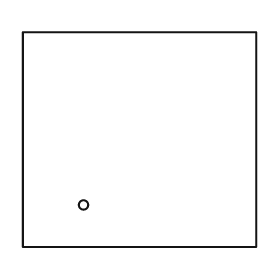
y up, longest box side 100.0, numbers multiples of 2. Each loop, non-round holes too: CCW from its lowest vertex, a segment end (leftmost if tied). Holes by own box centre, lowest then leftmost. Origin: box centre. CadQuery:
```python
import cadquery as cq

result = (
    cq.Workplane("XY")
    .moveTo(-50.0, -46.0)
    .lineTo(50.0, -46.0)
    .lineTo(50.0, 46.0)
    .lineTo(-50.0, 46.0)
    .close()
    .moveTo(-24.0, -28.0)
    .circle(2.0)
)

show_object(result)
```